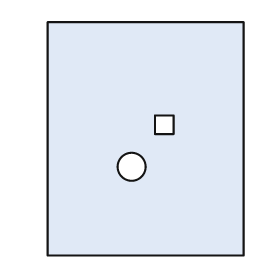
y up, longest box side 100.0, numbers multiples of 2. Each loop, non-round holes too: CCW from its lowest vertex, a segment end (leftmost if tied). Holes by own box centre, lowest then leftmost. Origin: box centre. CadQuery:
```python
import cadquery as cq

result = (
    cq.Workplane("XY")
    .moveTo(-42.0, -50.0)
    .lineTo(42.0, -50.0)
    .lineTo(42.0, 50.0)
    .lineTo(-42.0, 50.0)
    .close()
    .moveTo(-6.0, -12.0)
    .circle(6.0)
    .moveTo(4.0, 2.0)
    .lineTo(12.0, 2.0)
    .lineTo(12.0, 10.0)
    .lineTo(4.0, 10.0)
    .close()
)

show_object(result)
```